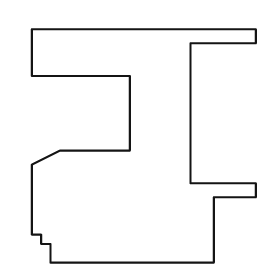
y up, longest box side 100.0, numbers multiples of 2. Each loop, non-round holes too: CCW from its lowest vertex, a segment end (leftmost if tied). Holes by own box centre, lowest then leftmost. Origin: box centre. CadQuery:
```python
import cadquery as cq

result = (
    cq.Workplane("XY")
    .moveTo(-40.0, -50.0)
    .lineTo(30.0, -50.0)
    .lineTo(30.0, -22.0)
    .lineTo(48.0, -22.0)
    .lineTo(48.0, -16.0)
    .lineTo(20.0, -16.0)
    .lineTo(20.0, 44.0)
    .lineTo(48.0, 44.0)
    .lineTo(48.0, 50.0)
    .lineTo(-48.0, 50.0)
    .lineTo(-48.0, 30.0)
    .lineTo(-6.0, 30.0)
    .lineTo(-6.0, -2.0)
    .lineTo(-36.0, -2.0)
    .lineTo(-48.0, -8.0)
    .lineTo(-48.0, -38.0)
    .lineTo(-44.0, -38.0)
    .lineTo(-44.0, -42.0)
    .lineTo(-40.0, -42.0)
    .close()
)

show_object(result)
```